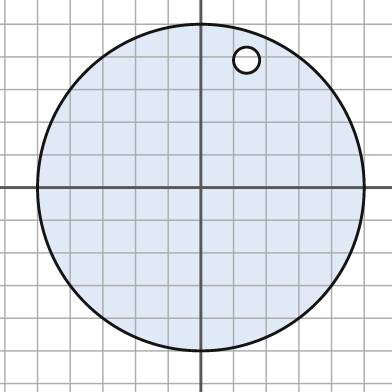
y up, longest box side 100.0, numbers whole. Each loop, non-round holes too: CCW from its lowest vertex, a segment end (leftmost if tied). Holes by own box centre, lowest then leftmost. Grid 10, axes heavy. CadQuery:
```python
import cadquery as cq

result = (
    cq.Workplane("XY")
    .moveTo(0.0, 0.0)
    .circle(50.0)
    .moveTo(14.0, 39.0)
    .circle(4.0)
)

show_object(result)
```